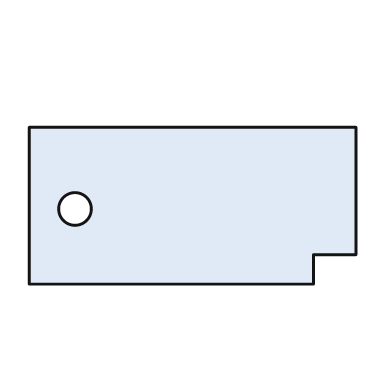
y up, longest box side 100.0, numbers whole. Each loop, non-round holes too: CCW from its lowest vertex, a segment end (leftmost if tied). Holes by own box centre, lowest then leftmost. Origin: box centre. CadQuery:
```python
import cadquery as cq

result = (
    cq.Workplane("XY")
    .moveTo(-50.0, -24.0)
    .lineTo(37.0, -24.0)
    .lineTo(37.0, -15.0)
    .lineTo(50.0, -15.0)
    .lineTo(50.0, 24.0)
    .lineTo(-50.0, 24.0)
    .close()
    .moveTo(-36.0, -1.0)
    .circle(5.0)
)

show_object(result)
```